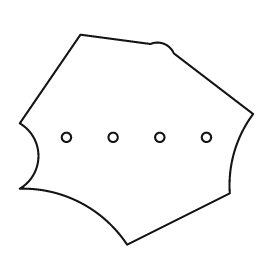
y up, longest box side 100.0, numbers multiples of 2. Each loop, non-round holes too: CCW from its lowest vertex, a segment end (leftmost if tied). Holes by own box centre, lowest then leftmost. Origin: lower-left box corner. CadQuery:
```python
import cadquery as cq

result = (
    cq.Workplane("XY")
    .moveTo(46.0, 0.0)
    .lineTo(90.0, 22.0)
    .threePointArc((92.0, 40.0), (100.0, 56.0))
    .lineTo(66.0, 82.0)
    .threePointArc((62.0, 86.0), (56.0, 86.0))
    .lineTo(26.0, 90.0)
    .lineTo(0.0, 52.0)
    .threePointArc((8.0, 38.0), (0.0, 24.0))
    .threePointArc((26.0, 18.0), (46.0, 0.0))
    .close()
    .moveTo(20.0, 46.0)
    .circle(2.0)
    .moveTo(40.0, 46.0)
    .circle(2.0)
    .moveTo(60.0, 46.0)
    .circle(2.0)
    .moveTo(80.0, 46.0)
    .circle(2.0)
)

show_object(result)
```